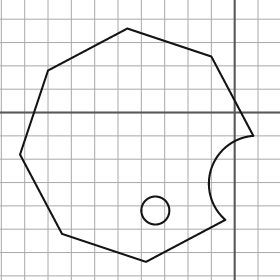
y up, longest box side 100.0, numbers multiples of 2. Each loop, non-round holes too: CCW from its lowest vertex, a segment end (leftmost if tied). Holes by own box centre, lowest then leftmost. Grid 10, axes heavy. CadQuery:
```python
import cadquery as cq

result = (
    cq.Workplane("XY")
    .moveTo(-38.0, -64.0)
    .lineTo(-4.0, -46.0)
    .threePointArc((-10.0, -24.0), (8.0, -10.0))
    .lineTo(-10.0, 24.0)
    .lineTo(-46.0, 36.0)
    .lineTo(-80.0, 18.0)
    .lineTo(-92.0, -18.0)
    .lineTo(-74.0, -52.0)
    .close()
    .moveTo(-34.0, -42.0)
    .circle(6.0)
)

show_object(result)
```